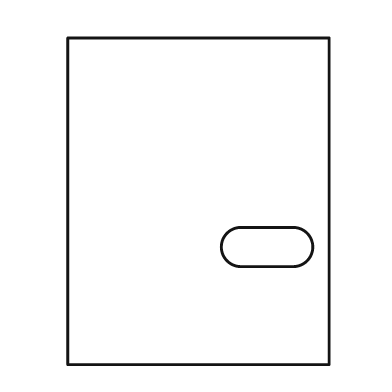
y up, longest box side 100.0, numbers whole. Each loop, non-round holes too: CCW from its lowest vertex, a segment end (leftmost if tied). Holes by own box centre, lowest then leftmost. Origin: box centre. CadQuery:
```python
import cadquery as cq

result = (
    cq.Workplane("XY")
    .moveTo(-40.0, -50.0)
    .lineTo(40.0, -50.0)
    .lineTo(40.0, 50.0)
    .lineTo(-40.0, 50.0)
    .close()
    .moveTo(13.0, -20.0)
    .lineTo(29.0, -20.0)
    .threePointArc((35.0, -14.0), (29.0, -8.0))
    .lineTo(13.0, -8.0)
    .threePointArc((7.0, -14.0), (13.0, -20.0))
    .close()
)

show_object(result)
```